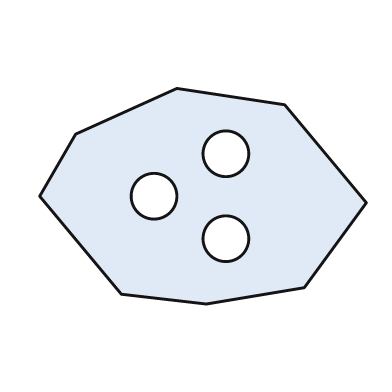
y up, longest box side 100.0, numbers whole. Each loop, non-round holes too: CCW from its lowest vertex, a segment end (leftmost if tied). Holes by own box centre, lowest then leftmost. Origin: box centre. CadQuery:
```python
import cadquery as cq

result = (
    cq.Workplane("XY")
    .moveTo(1.0, -33.0)
    .lineTo(31.0, -28.0)
    .lineTo(50.0, -2.0)
    .lineTo(25.0, 28.0)
    .lineTo(-8.0, 33.0)
    .lineTo(-39.0, 19.0)
    .lineTo(-50.0, 0.0)
    .lineTo(-25.0, -30.0)
    .close()
    .moveTo(7.0, -13.0)
    .circle(7.0)
    .moveTo(-15.0, 0.0)
    .circle(7.0)
    .moveTo(7.0, 13.0)
    .circle(7.0)
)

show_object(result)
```